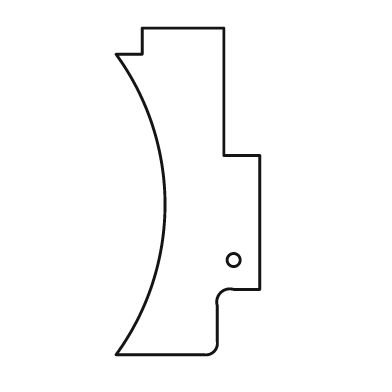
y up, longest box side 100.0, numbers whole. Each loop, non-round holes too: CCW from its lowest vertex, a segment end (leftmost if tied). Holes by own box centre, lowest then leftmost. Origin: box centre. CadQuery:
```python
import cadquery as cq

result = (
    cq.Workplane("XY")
    .moveTo(-22.0, -50.0)
    .lineTo(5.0, -50.0)
    .threePointArc((8.0, -49.0), (9.0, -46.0))
    .lineTo(9.0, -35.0)
    .threePointArc((10.0, -31.0), (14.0, -30.0))
    .lineTo(22.0, -30.0)
    .lineTo(22.0, 11.0)
    .lineTo(11.0, 11.0)
    .lineTo(11.0, 50.0)
    .lineTo(-14.0, 50.0)
    .lineTo(-14.0, 42.0)
    .lineTo(-22.0, 42.0)
    .threePointArc((-7.0, -4.0), (-22.0, -50.0))
    .close()
    .moveTo(14.0, -21.0)
    .circle(2.0)
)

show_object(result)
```